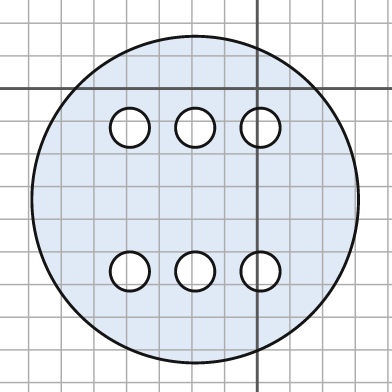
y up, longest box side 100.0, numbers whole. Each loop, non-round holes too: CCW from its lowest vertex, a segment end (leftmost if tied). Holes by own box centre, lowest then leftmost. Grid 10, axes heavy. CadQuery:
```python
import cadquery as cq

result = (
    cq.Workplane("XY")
    .moveTo(-19.0, -34.0)
    .circle(50.0)
    .moveTo(-39.0, -56.0)
    .circle(6.0)
    .moveTo(-19.0, -56.0)
    .circle(6.0)
    .moveTo(1.0, -56.0)
    .circle(6.0)
    .moveTo(-39.0, -12.0)
    .circle(6.0)
    .moveTo(-19.0, -12.0)
    .circle(6.0)
    .moveTo(1.0, -12.0)
    .circle(6.0)
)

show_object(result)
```